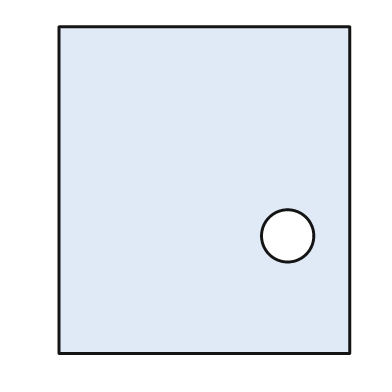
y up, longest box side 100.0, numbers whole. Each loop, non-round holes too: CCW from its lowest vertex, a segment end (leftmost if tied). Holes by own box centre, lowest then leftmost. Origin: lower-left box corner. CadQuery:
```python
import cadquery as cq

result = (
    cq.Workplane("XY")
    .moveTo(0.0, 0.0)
    .lineTo(89.0, 0.0)
    .lineTo(89.0, 100.0)
    .lineTo(0.0, 100.0)
    .close()
    .moveTo(70.0, 36.0)
    .circle(8.0)
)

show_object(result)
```